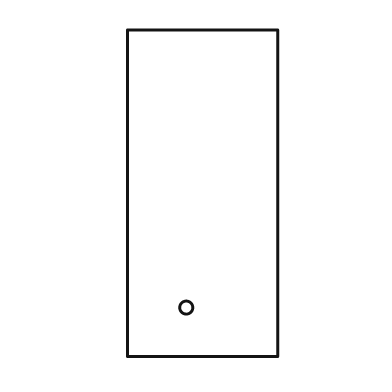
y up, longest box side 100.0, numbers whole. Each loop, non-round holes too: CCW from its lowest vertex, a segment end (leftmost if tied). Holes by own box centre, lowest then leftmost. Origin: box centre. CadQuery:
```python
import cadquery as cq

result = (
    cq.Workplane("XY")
    .moveTo(-23.0, -50.0)
    .lineTo(23.0, -50.0)
    .lineTo(23.0, 50.0)
    .lineTo(-23.0, 50.0)
    .close()
    .moveTo(-5.0, -35.0)
    .circle(2.0)
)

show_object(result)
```